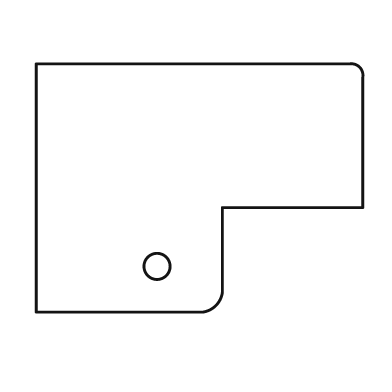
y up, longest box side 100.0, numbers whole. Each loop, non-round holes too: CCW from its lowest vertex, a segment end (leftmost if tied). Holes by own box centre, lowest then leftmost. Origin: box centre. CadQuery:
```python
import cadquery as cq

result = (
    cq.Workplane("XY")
    .moveTo(-50.0, -38.0)
    .lineTo(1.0, -38.0)
    .threePointArc((5.0, -36.0), (7.0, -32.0))
    .lineTo(7.0, -6.0)
    .lineTo(50.0, -6.0)
    .lineTo(50.0, 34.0)
    .threePointArc((49.0, 37.0), (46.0, 38.0))
    .lineTo(-50.0, 38.0)
    .close()
    .moveTo(-13.0, -24.0)
    .circle(4.0)
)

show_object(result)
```